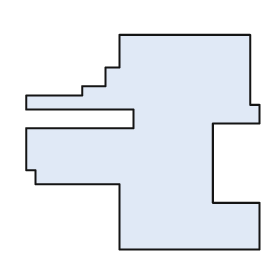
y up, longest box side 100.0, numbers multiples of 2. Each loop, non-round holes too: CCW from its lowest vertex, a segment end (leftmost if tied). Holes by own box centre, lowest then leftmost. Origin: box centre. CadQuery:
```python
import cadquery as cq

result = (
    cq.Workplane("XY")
    .moveTo(-10.0, -46.0)
    .lineTo(50.0, -46.0)
    .lineTo(50.0, -26.0)
    .lineTo(30.0, -26.0)
    .lineTo(30.0, 8.0)
    .lineTo(50.0, 8.0)
    .lineTo(50.0, 16.0)
    .lineTo(46.0, 16.0)
    .lineTo(46.0, 46.0)
    .lineTo(-10.0, 46.0)
    .lineTo(-10.0, 32.0)
    .lineTo(-16.0, 32.0)
    .lineTo(-16.0, 24.0)
    .lineTo(-26.0, 24.0)
    .lineTo(-26.0, 20.0)
    .lineTo(-50.0, 20.0)
    .lineTo(-50.0, 14.0)
    .lineTo(-4.0, 14.0)
    .lineTo(-4.0, 6.0)
    .lineTo(-50.0, 6.0)
    .lineTo(-50.0, -12.0)
    .lineTo(-46.0, -12.0)
    .lineTo(-46.0, -18.0)
    .lineTo(-10.0, -18.0)
    .close()
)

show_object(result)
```